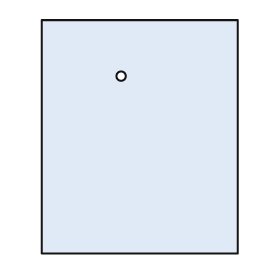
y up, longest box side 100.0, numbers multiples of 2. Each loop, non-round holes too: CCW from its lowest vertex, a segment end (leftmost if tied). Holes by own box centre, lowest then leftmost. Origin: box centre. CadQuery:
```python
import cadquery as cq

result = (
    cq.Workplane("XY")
    .moveTo(-42.0, -50.0)
    .lineTo(42.0, -50.0)
    .lineTo(42.0, 50.0)
    .lineTo(-42.0, 50.0)
    .close()
    .moveTo(-8.0, 26.0)
    .circle(2.0)
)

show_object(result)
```